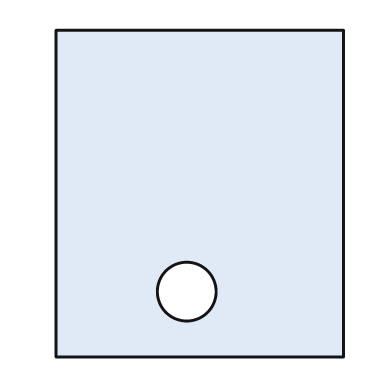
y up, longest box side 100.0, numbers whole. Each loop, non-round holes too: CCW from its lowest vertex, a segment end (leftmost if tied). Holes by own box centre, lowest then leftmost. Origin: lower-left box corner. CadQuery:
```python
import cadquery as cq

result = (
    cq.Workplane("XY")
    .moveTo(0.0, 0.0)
    .lineTo(88.0, 0.0)
    .lineTo(88.0, 100.0)
    .lineTo(0.0, 100.0)
    .close()
    .moveTo(40.0, 20.0)
    .circle(9.0)
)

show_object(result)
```